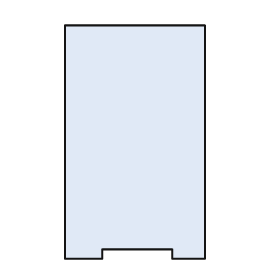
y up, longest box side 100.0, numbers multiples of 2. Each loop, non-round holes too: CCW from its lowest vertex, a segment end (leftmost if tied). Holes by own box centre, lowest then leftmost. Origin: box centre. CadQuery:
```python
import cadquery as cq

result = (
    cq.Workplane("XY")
    .moveTo(-30.0, -50.0)
    .lineTo(-14.0, -50.0)
    .lineTo(-14.0, -46.0)
    .lineTo(16.0, -46.0)
    .lineTo(16.0, -50.0)
    .lineTo(30.0, -50.0)
    .lineTo(30.0, 50.0)
    .lineTo(-30.0, 50.0)
    .close()
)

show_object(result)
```